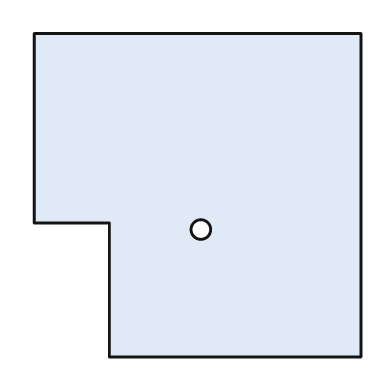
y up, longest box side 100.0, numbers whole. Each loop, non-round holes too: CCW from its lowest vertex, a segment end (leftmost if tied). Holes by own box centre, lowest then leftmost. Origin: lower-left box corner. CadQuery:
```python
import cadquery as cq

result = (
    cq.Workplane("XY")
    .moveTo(23.0, 0.0)
    .lineTo(100.0, 0.0)
    .lineTo(100.0, 99.0)
    .lineTo(0.0, 99.0)
    .lineTo(0.0, 41.0)
    .lineTo(23.0, 41.0)
    .close()
    .moveTo(51.0, 39.0)
    .circle(3.0)
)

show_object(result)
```